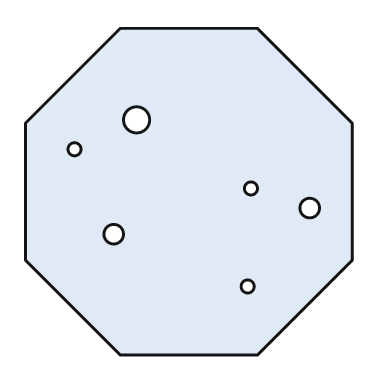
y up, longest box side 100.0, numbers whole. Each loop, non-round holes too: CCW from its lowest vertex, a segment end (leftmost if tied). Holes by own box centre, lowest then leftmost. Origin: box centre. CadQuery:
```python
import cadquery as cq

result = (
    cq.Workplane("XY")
    .moveTo(-21.0, -50.0)
    .lineTo(21.0, -50.0)
    .lineTo(50.0, -21.0)
    .lineTo(50.0, 21.0)
    .lineTo(21.0, 50.0)
    .lineTo(-21.0, 50.0)
    .lineTo(-50.0, 21.0)
    .lineTo(-50.0, -21.0)
    .close()
    .moveTo(18.0, -29.0)
    .circle(2.0)
    .moveTo(-23.0, -13.0)
    .circle(3.0)
    .moveTo(37.0, -5.0)
    .circle(3.0)
    .moveTo(19.0, 1.0)
    .circle(2.0)
    .moveTo(-35.0, 13.0)
    .circle(2.0)
    .moveTo(-16.0, 22.0)
    .circle(4.0)
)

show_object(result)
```